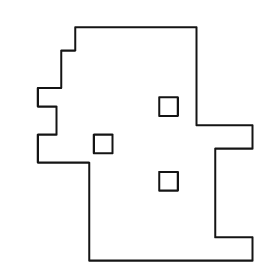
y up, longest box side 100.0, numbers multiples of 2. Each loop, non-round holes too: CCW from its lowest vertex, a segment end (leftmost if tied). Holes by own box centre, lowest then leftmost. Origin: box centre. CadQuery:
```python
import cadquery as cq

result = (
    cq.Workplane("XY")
    .moveTo(-24.0, -50.0)
    .lineTo(46.0, -50.0)
    .lineTo(46.0, -40.0)
    .lineTo(30.0, -40.0)
    .lineTo(30.0, -2.0)
    .lineTo(46.0, -2.0)
    .lineTo(46.0, 8.0)
    .lineTo(22.0, 8.0)
    .lineTo(22.0, 50.0)
    .lineTo(-30.0, 50.0)
    .lineTo(-30.0, 40.0)
    .lineTo(-36.0, 40.0)
    .lineTo(-36.0, 24.0)
    .lineTo(-46.0, 24.0)
    .lineTo(-46.0, 16.0)
    .lineTo(-38.0, 16.0)
    .lineTo(-38.0, 4.0)
    .lineTo(-46.0, 4.0)
    .lineTo(-46.0, -8.0)
    .lineTo(-24.0, -8.0)
    .close()
    .moveTo(6.0, -20.0)
    .lineTo(14.0, -20.0)
    .lineTo(14.0, -12.0)
    .lineTo(6.0, -12.0)
    .close()
    .moveTo(-22.0, -4.0)
    .lineTo(-14.0, -4.0)
    .lineTo(-14.0, 4.0)
    .lineTo(-22.0, 4.0)
    .close()
    .moveTo(6.0, 12.0)
    .lineTo(14.0, 12.0)
    .lineTo(14.0, 20.0)
    .lineTo(6.0, 20.0)
    .close()
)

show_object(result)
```